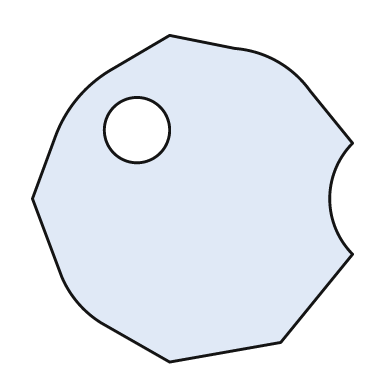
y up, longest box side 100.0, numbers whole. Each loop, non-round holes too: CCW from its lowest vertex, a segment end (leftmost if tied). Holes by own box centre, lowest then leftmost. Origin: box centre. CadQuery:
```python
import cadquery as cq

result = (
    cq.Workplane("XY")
    .moveTo(-7.0, -50.0)
    .lineTo(27.0, -44.0)
    .lineTo(49.0, -17.0)
    .threePointArc((42.0, 0.0), (49.0, 17.0))
    .lineTo(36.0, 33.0)
    .threePointArc((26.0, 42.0), (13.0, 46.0))
    .lineTo(-7.0, 50.0)
    .lineTo(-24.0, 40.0)
    .threePointArc((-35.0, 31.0), (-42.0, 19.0))
    .lineTo(-49.0, 0.0)
    .lineTo(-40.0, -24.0)
    .threePointArc((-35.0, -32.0), (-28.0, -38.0))
    .close()
    .moveTo(-17.0, 21.0)
    .circle(10.0)
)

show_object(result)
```